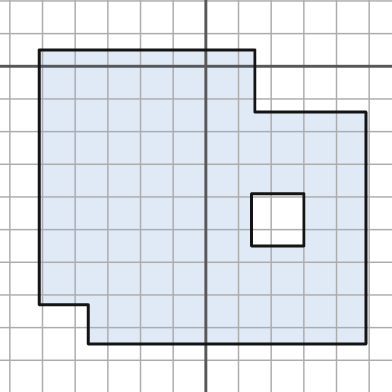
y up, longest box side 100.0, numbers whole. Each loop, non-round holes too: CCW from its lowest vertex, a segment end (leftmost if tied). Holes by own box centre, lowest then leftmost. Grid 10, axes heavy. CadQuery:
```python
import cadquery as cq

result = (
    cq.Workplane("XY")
    .moveTo(-36.0, -85.0)
    .lineTo(49.0, -85.0)
    .lineTo(49.0, -14.0)
    .lineTo(15.0, -14.0)
    .lineTo(15.0, 5.0)
    .lineTo(-51.0, 5.0)
    .lineTo(-51.0, -73.0)
    .lineTo(-36.0, -73.0)
    .close()
    .moveTo(14.0, -55.0)
    .lineTo(30.0, -55.0)
    .lineTo(30.0, -39.0)
    .lineTo(14.0, -39.0)
    .close()
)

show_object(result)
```